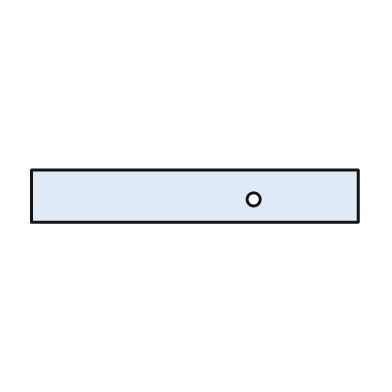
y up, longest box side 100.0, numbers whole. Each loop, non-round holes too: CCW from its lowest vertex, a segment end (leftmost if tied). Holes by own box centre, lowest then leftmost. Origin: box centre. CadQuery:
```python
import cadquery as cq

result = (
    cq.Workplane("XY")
    .moveTo(-50.0, -8.0)
    .lineTo(50.0, -8.0)
    .lineTo(50.0, 8.0)
    .lineTo(-50.0, 8.0)
    .close()
    .moveTo(18.0, -1.0)
    .circle(2.0)
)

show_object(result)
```